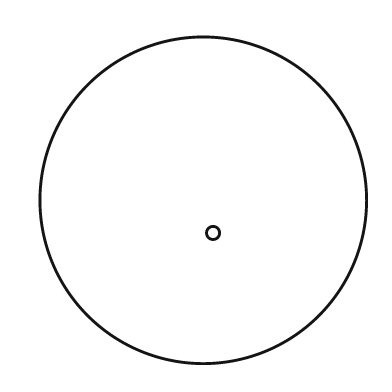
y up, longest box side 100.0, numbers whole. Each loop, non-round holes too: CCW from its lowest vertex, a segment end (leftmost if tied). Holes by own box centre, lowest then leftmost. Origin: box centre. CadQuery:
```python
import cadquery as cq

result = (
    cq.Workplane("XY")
    .moveTo(0.0, 0.0)
    .circle(50.0)
    .moveTo(3.0, -10.0)
    .circle(2.0)
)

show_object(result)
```